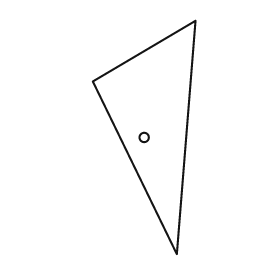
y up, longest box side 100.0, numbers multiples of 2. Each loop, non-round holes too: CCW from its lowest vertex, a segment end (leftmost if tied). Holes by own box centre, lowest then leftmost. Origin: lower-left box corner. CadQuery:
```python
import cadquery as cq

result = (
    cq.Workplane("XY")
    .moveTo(36.0, 0.0)
    .lineTo(44.0, 100.0)
    .lineTo(0.0, 74.0)
    .close()
    .moveTo(22.0, 50.0)
    .circle(2.0)
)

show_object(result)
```